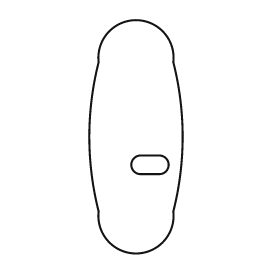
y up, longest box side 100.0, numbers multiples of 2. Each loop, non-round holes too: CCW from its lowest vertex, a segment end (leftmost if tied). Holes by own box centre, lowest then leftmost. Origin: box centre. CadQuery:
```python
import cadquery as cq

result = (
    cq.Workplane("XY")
    .moveTo(-16.0, -32.0)
    .threePointArc((0.0, -50.0), (16.0, -32.0))
    .threePointArc((20.0, 0.0), (16.0, 32.0))
    .threePointArc((0.0, 50.0), (-16.0, 32.0))
    .threePointArc((-20.0, 0.0), (-16.0, -32.0))
    .close()
    .moveTo(2.0, -16.0)
    .lineTo(10.0, -16.0)
    .threePointArc((14.0, -12.0), (10.0, -8.0))
    .lineTo(2.0, -8.0)
    .threePointArc((-2.0, -12.0), (2.0, -16.0))
    .close()
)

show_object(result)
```